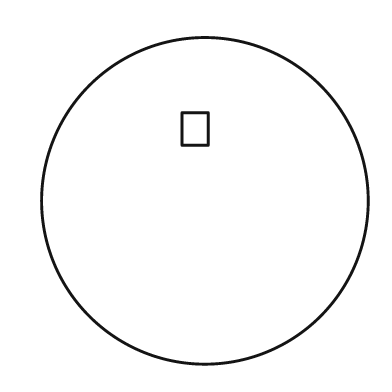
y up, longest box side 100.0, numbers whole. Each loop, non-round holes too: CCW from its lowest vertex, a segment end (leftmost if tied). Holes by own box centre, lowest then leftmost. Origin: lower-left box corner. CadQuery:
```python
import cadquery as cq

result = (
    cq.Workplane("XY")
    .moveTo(50.0, 50.0)
    .circle(50.0)
    .moveTo(43.0, 67.0)
    .lineTo(51.0, 67.0)
    .lineTo(51.0, 77.0)
    .lineTo(43.0, 77.0)
    .close()
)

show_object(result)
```